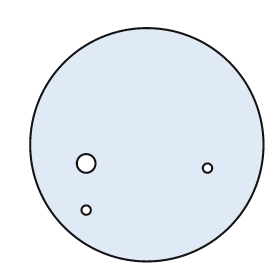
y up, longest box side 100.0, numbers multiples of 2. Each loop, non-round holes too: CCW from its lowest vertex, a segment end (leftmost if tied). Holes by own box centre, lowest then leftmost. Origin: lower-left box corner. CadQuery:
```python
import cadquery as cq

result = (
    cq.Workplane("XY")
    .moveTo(50.0, 50.0)
    .circle(50.0)
    .moveTo(24.0, 22.0)
    .circle(2.0)
    .moveTo(76.0, 40.0)
    .circle(2.0)
    .moveTo(24.0, 42.0)
    .circle(4.0)
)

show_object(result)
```